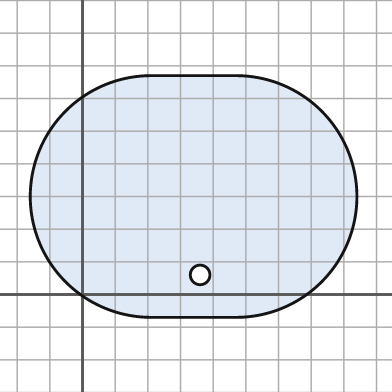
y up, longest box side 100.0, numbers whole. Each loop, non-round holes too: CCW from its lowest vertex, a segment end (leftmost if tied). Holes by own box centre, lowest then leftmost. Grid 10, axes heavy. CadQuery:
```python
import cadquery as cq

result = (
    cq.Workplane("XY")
    .moveTo(21.0, -7.0)
    .lineTo(47.0, -7.0)
    .threePointArc((84.0, 30.0), (47.0, 67.0))
    .lineTo(21.0, 67.0)
    .threePointArc((-16.0, 30.0), (21.0, -7.0))
    .close()
    .moveTo(36.0, 6.0)
    .circle(3.0)
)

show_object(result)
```